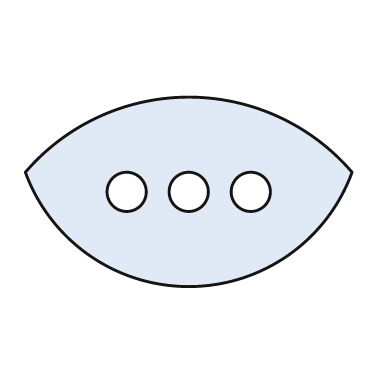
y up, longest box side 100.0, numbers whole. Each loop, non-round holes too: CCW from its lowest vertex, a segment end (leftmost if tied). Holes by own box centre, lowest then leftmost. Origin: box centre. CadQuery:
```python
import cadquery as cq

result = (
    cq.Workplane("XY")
    .moveTo(-50.0, 6.0)
    .threePointArc((0.0, -29.0), (50.0, 6.0))
    .threePointArc((0.0, 29.0), (-50.0, 6.0))
    .close()
    .moveTo(-19.0, 0.0)
    .circle(6.0)
    .moveTo(0.0, 0.0)
    .circle(6.0)
    .moveTo(19.0, 0.0)
    .circle(6.0)
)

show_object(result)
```